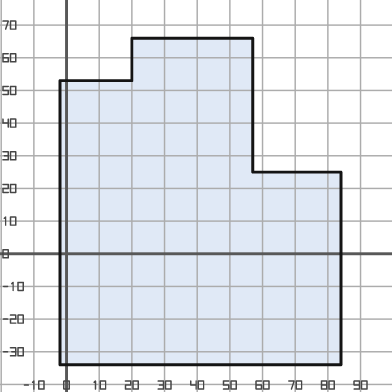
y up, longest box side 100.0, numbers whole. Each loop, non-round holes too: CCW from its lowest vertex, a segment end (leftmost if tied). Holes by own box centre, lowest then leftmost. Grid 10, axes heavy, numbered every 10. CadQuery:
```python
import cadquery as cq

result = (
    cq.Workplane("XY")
    .moveTo(-2.0, -34.0)
    .lineTo(84.0, -34.0)
    .lineTo(84.0, 25.0)
    .lineTo(57.0, 25.0)
    .lineTo(57.0, 66.0)
    .lineTo(20.0, 66.0)
    .lineTo(20.0, 53.0)
    .lineTo(-2.0, 53.0)
    .close()
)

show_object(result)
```